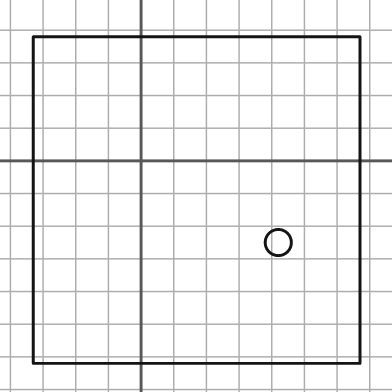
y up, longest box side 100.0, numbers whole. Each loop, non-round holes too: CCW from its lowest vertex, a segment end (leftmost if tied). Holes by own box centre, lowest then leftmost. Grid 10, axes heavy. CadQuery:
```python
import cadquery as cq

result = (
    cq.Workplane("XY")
    .moveTo(-33.0, -62.0)
    .lineTo(67.0, -62.0)
    .lineTo(67.0, 38.0)
    .lineTo(-33.0, 38.0)
    .close()
    .moveTo(42.0, -25.0)
    .circle(4.0)
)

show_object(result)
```